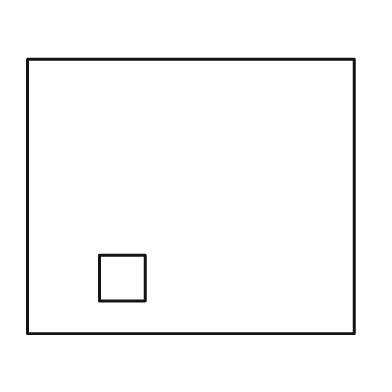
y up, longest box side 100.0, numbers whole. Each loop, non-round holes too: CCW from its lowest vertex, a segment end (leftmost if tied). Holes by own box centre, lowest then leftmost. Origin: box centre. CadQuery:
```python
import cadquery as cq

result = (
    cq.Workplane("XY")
    .moveTo(-50.0, -42.0)
    .lineTo(50.0, -42.0)
    .lineTo(50.0, 42.0)
    .lineTo(-50.0, 42.0)
    .close()
    .moveTo(-28.0, -32.0)
    .lineTo(-14.0, -32.0)
    .lineTo(-14.0, -18.0)
    .lineTo(-28.0, -18.0)
    .close()
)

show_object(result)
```